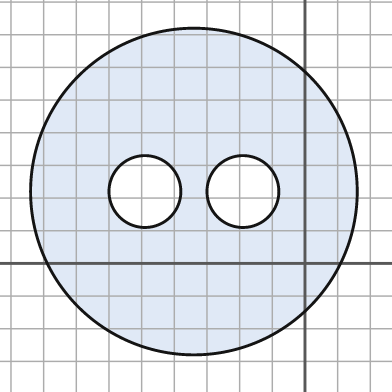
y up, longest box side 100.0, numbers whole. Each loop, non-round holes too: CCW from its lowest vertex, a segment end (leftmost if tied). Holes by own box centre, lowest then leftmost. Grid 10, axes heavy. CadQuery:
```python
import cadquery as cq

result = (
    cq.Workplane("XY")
    .moveTo(-34.0, 22.0)
    .circle(50.0)
    .moveTo(-49.0, 22.0)
    .circle(11.0)
    .moveTo(-19.0, 22.0)
    .circle(11.0)
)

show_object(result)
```